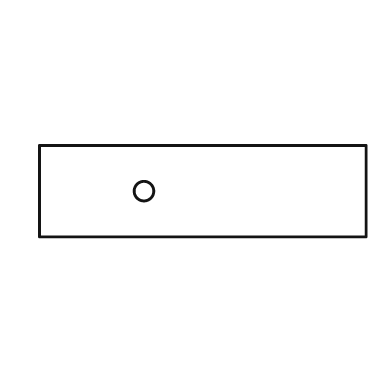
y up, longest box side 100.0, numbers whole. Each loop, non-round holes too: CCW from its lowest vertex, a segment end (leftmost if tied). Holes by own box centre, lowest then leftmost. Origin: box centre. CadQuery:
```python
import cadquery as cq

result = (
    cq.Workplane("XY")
    .moveTo(-50.0, -14.0)
    .lineTo(50.0, -14.0)
    .lineTo(50.0, 14.0)
    .lineTo(-50.0, 14.0)
    .close()
    .moveTo(-18.0, 0.0)
    .circle(3.0)
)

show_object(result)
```